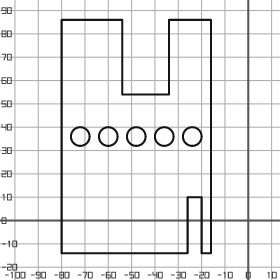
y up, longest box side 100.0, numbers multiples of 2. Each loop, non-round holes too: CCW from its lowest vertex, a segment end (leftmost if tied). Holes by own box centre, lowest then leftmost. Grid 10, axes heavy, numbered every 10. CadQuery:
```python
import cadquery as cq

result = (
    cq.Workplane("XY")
    .moveTo(-80.0, -14.0)
    .lineTo(-26.0, -14.0)
    .lineTo(-26.0, 10.0)
    .lineTo(-20.0, 10.0)
    .lineTo(-20.0, -14.0)
    .lineTo(-16.0, -14.0)
    .lineTo(-16.0, 86.0)
    .lineTo(-34.0, 86.0)
    .lineTo(-34.0, 54.0)
    .lineTo(-54.0, 54.0)
    .lineTo(-54.0, 86.0)
    .lineTo(-80.0, 86.0)
    .close()
    .moveTo(-72.0, 36.0)
    .circle(4.0)
    .moveTo(-60.0, 36.0)
    .circle(4.0)
    .moveTo(-48.0, 36.0)
    .circle(4.0)
    .moveTo(-36.0, 36.0)
    .circle(4.0)
    .moveTo(-24.0, 36.0)
    .circle(4.0)
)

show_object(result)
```